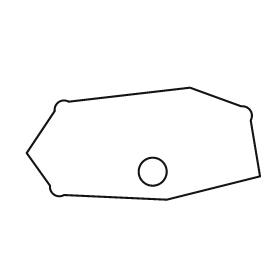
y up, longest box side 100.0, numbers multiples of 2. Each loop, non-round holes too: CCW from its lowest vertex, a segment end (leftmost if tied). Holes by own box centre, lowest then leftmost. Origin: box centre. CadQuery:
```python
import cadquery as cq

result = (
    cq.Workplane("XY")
    .moveTo(10.0, -24.0)
    .lineTo(50.0, -14.0)
    .lineTo(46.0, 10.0)
    .threePointArc((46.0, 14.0), (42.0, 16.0))
    .lineTo(20.0, 24.0)
    .lineTo(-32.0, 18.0)
    .threePointArc((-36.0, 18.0), (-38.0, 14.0))
    .lineTo(-50.0, -4.0)
    .lineTo(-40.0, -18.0)
    .threePointArc((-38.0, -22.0), (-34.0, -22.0))
    .close()
    .moveTo(4.0, -12.0)
    .circle(6.0)
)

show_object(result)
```